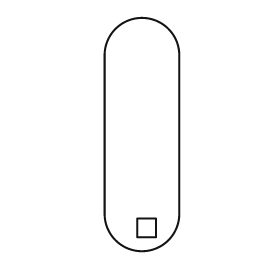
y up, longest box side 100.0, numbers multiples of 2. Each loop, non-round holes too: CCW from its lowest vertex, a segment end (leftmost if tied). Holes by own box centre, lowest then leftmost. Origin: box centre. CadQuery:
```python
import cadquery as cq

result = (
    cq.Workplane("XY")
    .moveTo(-16.0, -34.0)
    .threePointArc((0.0, -50.0), (16.0, -34.0))
    .lineTo(16.0, 34.0)
    .threePointArc((0.0, 50.0), (-16.0, 34.0))
    .close()
    .moveTo(-2.0, -44.0)
    .lineTo(6.0, -44.0)
    .lineTo(6.0, -36.0)
    .lineTo(-2.0, -36.0)
    .close()
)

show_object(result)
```